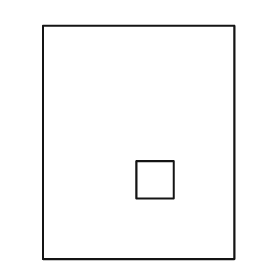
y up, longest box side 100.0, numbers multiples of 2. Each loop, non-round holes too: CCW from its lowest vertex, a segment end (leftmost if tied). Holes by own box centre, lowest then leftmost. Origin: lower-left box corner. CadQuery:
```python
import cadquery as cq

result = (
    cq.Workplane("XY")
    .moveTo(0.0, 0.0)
    .lineTo(82.0, 0.0)
    .lineTo(82.0, 100.0)
    .lineTo(0.0, 100.0)
    .close()
    .moveTo(40.0, 26.0)
    .lineTo(56.0, 26.0)
    .lineTo(56.0, 42.0)
    .lineTo(40.0, 42.0)
    .close()
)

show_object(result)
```